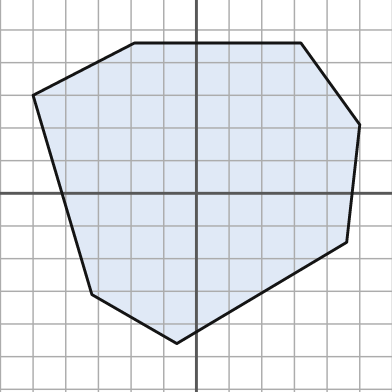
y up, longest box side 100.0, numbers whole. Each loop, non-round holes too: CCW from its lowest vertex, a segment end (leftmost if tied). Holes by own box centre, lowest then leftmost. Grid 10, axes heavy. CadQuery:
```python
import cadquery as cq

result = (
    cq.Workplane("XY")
    .moveTo(-6.0, -46.0)
    .lineTo(46.0, -15.0)
    .lineTo(50.0, 21.0)
    .lineTo(32.0, 46.0)
    .lineTo(-19.0, 46.0)
    .lineTo(-50.0, 30.0)
    .lineTo(-32.0, -31.0)
    .close()
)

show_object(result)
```